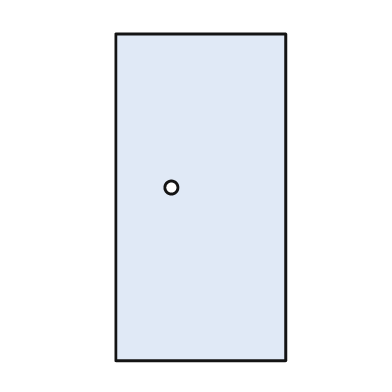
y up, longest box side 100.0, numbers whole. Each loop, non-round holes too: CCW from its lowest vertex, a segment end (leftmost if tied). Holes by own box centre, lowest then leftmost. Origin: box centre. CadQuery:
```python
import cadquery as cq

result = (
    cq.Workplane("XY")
    .moveTo(-26.0, -50.0)
    .lineTo(26.0, -50.0)
    .lineTo(26.0, 50.0)
    .lineTo(-26.0, 50.0)
    .close()
    .moveTo(-9.0, 3.0)
    .circle(2.0)
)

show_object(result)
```